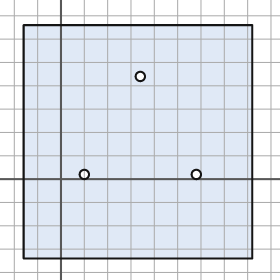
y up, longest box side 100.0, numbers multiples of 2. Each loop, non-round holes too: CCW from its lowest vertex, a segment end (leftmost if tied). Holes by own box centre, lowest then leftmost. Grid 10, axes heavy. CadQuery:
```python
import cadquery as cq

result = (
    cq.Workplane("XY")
    .moveTo(-16.0, -34.0)
    .lineTo(82.0, -34.0)
    .lineTo(82.0, 66.0)
    .lineTo(-16.0, 66.0)
    .close()
    .moveTo(10.0, 2.0)
    .circle(2.0)
    .moveTo(58.0, 2.0)
    .circle(2.0)
    .moveTo(34.0, 44.0)
    .circle(2.0)
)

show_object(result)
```